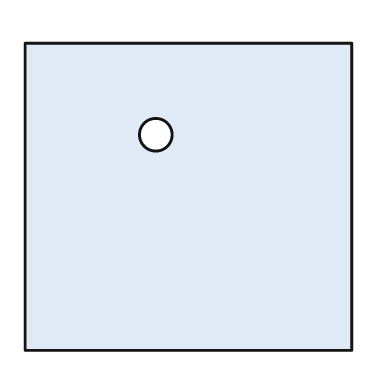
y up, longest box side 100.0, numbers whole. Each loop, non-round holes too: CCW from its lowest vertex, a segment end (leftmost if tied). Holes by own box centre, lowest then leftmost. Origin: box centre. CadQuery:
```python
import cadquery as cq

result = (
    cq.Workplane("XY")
    .moveTo(-50.0, -47.0)
    .lineTo(50.0, -47.0)
    .lineTo(50.0, 47.0)
    .lineTo(-50.0, 47.0)
    .close()
    .moveTo(-10.0, 19.0)
    .circle(5.0)
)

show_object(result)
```